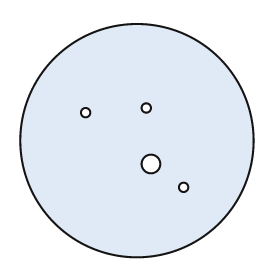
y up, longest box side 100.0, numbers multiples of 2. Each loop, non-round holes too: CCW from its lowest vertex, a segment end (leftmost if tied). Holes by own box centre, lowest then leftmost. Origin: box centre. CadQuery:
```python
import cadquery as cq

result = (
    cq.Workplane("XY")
    .moveTo(0.0, 0.0)
    .circle(50.0)
    .moveTo(20.0, -20.0)
    .circle(2.0)
    .moveTo(6.0, -10.0)
    .circle(4.0)
    .moveTo(-22.0, 12.0)
    .circle(2.0)
    .moveTo(4.0, 14.0)
    .circle(2.0)
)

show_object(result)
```